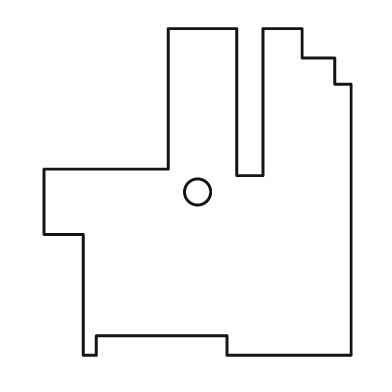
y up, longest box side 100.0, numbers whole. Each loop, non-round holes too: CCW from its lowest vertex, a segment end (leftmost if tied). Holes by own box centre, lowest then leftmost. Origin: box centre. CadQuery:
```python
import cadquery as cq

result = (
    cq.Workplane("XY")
    .moveTo(-35.0, -50.0)
    .lineTo(-31.0, -50.0)
    .lineTo(-31.0, -44.0)
    .lineTo(9.0, -44.0)
    .lineTo(9.0, -50.0)
    .lineTo(47.0, -50.0)
    .lineTo(47.0, 33.0)
    .lineTo(42.0, 33.0)
    .lineTo(42.0, 41.0)
    .lineTo(32.0, 41.0)
    .lineTo(32.0, 50.0)
    .lineTo(20.0, 50.0)
    .lineTo(20.0, 5.0)
    .lineTo(12.0, 5.0)
    .lineTo(12.0, 50.0)
    .lineTo(-9.0, 50.0)
    .lineTo(-9.0, 7.0)
    .lineTo(-47.0, 7.0)
    .lineTo(-47.0, -13.0)
    .lineTo(-35.0, -13.0)
    .close()
    .moveTo(0.0, 0.0)
    .circle(4.0)
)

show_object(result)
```